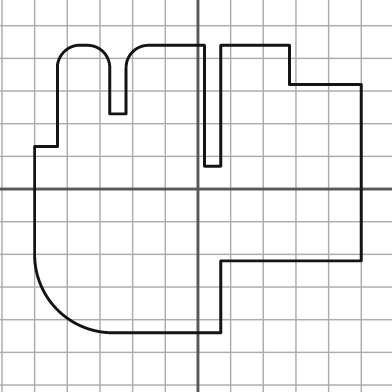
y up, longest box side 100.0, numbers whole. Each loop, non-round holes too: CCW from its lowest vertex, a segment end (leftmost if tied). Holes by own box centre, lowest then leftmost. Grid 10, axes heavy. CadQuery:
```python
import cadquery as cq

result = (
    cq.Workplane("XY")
    .moveTo(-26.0, -44.0)
    .lineTo(7.0, -44.0)
    .lineTo(7.0, -22.0)
    .lineTo(50.0, -22.0)
    .lineTo(50.0, 32.0)
    .lineTo(28.0, 32.0)
    .lineTo(28.0, 44.0)
    .lineTo(7.0, 44.0)
    .lineTo(7.0, 7.0)
    .lineTo(2.0, 7.0)
    .lineTo(2.0, 44.0)
    .lineTo(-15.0, 44.0)
    .threePointArc((-20.0, 42.0), (-22.0, 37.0))
    .lineTo(-22.0, 23.0)
    .lineTo(-27.0, 23.0)
    .lineTo(-27.0, 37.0)
    .threePointArc((-29.0, 42.0), (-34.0, 44.0))
    .lineTo(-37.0, 44.0)
    .threePointArc((-41.0, 42.0), (-43.0, 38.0))
    .lineTo(-43.0, 13.0)
    .lineTo(-50.0, 13.0)
    .lineTo(-50.0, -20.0)
    .threePointArc((-43.0, -37.0), (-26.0, -44.0))
    .close()
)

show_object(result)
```